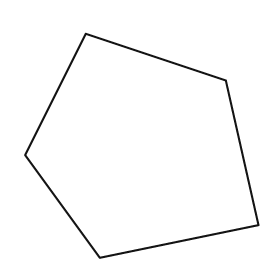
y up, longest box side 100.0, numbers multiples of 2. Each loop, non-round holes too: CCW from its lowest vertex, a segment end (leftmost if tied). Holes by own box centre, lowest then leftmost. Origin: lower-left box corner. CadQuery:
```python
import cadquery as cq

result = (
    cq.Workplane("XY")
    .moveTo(32.0, 0.0)
    .lineTo(100.0, 14.0)
    .lineTo(86.0, 76.0)
    .lineTo(26.0, 96.0)
    .lineTo(0.0, 44.0)
    .close()
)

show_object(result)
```